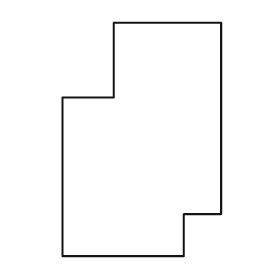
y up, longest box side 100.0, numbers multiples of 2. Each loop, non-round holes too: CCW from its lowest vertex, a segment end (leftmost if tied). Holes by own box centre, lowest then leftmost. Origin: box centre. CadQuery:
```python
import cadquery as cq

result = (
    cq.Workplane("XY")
    .moveTo(-34.0, -50.0)
    .lineTo(18.0, -50.0)
    .lineTo(18.0, -32.0)
    .lineTo(34.0, -32.0)
    .lineTo(34.0, 50.0)
    .lineTo(-12.0, 50.0)
    .lineTo(-12.0, 18.0)
    .lineTo(-34.0, 18.0)
    .close()
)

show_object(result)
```